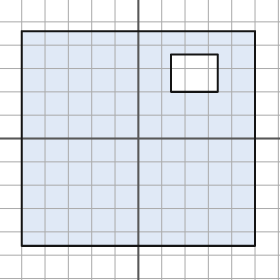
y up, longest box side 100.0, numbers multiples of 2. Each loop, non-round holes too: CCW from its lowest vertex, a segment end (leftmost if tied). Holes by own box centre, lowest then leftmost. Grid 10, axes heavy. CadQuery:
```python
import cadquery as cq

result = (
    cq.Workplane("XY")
    .moveTo(-50.0, -46.0)
    .lineTo(50.0, -46.0)
    .lineTo(50.0, 46.0)
    .lineTo(-50.0, 46.0)
    .close()
    .moveTo(14.0, 20.0)
    .lineTo(34.0, 20.0)
    .lineTo(34.0, 36.0)
    .lineTo(14.0, 36.0)
    .close()
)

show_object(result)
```